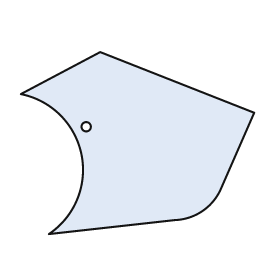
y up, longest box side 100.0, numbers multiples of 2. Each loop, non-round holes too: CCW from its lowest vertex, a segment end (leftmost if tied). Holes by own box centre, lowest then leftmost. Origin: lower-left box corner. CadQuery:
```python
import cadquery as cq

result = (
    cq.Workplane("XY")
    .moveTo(12.0, 0.0)
    .lineTo(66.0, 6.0)
    .threePointArc((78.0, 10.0), (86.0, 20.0))
    .lineTo(100.0, 52.0)
    .lineTo(34.0, 78.0)
    .lineTo(0.0, 60.0)
    .threePointArc((26.0, 34.0), (12.0, 0.0))
    .close()
    .moveTo(28.0, 46.0)
    .circle(2.0)
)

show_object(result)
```